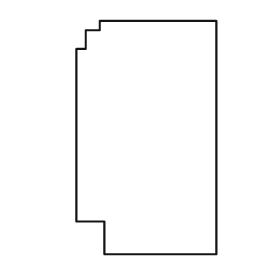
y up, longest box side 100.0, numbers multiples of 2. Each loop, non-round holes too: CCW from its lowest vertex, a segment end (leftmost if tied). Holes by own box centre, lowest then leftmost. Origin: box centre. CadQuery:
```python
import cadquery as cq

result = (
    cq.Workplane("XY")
    .moveTo(-18.0, -50.0)
    .lineTo(30.0, -50.0)
    .lineTo(30.0, 50.0)
    .lineTo(-20.0, 50.0)
    .lineTo(-20.0, 46.0)
    .lineTo(-26.0, 46.0)
    .lineTo(-26.0, 38.0)
    .lineTo(-30.0, 38.0)
    .lineTo(-30.0, -36.0)
    .lineTo(-18.0, -36.0)
    .close()
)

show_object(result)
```